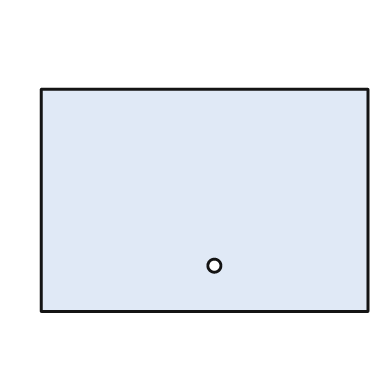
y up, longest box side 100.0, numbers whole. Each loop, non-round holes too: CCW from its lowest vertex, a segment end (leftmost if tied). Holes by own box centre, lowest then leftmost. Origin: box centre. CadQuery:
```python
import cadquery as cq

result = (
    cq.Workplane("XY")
    .moveTo(-50.0, -34.0)
    .lineTo(50.0, -34.0)
    .lineTo(50.0, 34.0)
    .lineTo(-50.0, 34.0)
    .close()
    .moveTo(3.0, -20.0)
    .circle(2.0)
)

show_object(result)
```